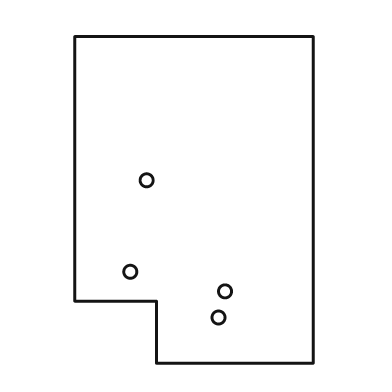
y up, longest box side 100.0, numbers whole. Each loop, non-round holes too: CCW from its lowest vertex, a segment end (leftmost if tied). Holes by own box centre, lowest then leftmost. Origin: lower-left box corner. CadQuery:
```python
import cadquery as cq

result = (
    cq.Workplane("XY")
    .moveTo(25.0, 0.0)
    .lineTo(73.0, 0.0)
    .lineTo(73.0, 100.0)
    .lineTo(0.0, 100.0)
    .lineTo(0.0, 19.0)
    .lineTo(25.0, 19.0)
    .close()
    .moveTo(44.0, 14.0)
    .circle(2.0)
    .moveTo(46.0, 22.0)
    .circle(2.0)
    .moveTo(17.0, 28.0)
    .circle(2.0)
    .moveTo(22.0, 56.0)
    .circle(2.0)
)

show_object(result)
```